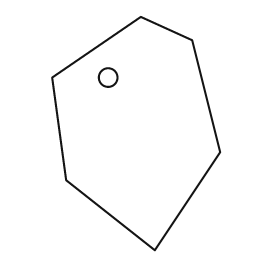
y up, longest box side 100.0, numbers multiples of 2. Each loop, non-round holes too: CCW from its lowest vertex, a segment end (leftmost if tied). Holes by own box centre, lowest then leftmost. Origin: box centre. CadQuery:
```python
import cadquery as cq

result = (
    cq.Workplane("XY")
    .moveTo(8.0, -50.0)
    .lineTo(36.0, -8.0)
    .lineTo(24.0, 40.0)
    .lineTo(2.0, 50.0)
    .lineTo(-36.0, 24.0)
    .lineTo(-30.0, -20.0)
    .close()
    .moveTo(-12.0, 24.0)
    .circle(4.0)
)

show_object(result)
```